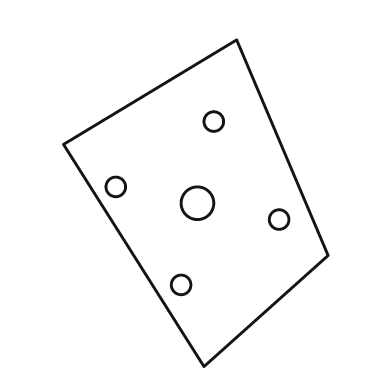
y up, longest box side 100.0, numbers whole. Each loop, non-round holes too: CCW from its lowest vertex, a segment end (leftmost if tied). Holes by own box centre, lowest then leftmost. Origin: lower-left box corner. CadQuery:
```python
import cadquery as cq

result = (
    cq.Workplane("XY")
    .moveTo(43.0, 0.0)
    .lineTo(81.0, 34.0)
    .lineTo(53.0, 100.0)
    .lineTo(0.0, 68.0)
    .close()
    .moveTo(36.0, 25.0)
    .circle(3.0)
    .moveTo(66.0, 45.0)
    .circle(3.0)
    .moveTo(41.0, 50.0)
    .circle(5.0)
    .moveTo(16.0, 55.0)
    .circle(3.0)
    .moveTo(46.0, 75.0)
    .circle(3.0)
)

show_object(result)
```